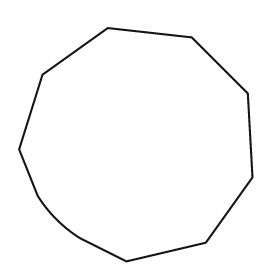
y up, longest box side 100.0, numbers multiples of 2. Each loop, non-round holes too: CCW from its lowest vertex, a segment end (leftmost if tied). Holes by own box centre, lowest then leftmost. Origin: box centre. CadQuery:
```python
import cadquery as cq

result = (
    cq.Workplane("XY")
    .moveTo(-4.0, -50.0)
    .lineTo(30.0, -42.0)
    .lineTo(50.0, -14.0)
    .lineTo(48.0, 22.0)
    .lineTo(24.0, 46.0)
    .lineTo(-12.0, 50.0)
    .lineTo(-40.0, 30.0)
    .lineTo(-50.0, -2.0)
    .lineTo(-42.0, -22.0)
    .threePointArc((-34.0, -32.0), (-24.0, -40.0))
    .close()
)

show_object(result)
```